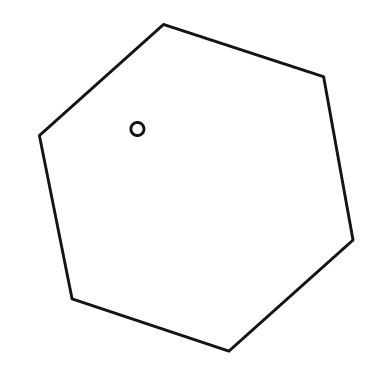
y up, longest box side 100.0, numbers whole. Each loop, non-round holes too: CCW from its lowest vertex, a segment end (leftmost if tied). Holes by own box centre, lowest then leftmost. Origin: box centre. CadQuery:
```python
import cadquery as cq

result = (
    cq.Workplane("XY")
    .moveTo(10.0, -50.0)
    .lineTo(48.0, -16.0)
    .lineTo(39.0, 34.0)
    .lineTo(-10.0, 50.0)
    .lineTo(-48.0, 16.0)
    .lineTo(-38.0, -34.0)
    .close()
    .moveTo(-18.0, 18.0)
    .circle(2.0)
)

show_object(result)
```